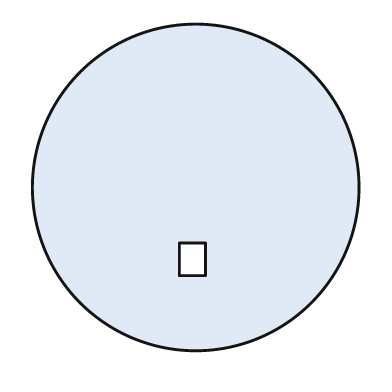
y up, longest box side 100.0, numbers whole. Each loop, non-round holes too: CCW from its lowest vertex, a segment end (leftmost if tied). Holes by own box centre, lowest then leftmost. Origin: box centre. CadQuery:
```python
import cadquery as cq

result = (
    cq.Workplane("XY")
    .moveTo(0.0, 0.0)
    .circle(50.0)
    .moveTo(-5.0, -27.0)
    .lineTo(3.0, -27.0)
    .lineTo(3.0, -17.0)
    .lineTo(-5.0, -17.0)
    .close()
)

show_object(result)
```